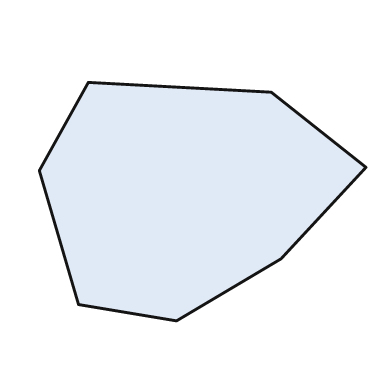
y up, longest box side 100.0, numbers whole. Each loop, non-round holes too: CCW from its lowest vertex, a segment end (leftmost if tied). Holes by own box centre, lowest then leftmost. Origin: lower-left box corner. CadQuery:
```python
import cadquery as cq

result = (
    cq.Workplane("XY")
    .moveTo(42.0, 0.0)
    .lineTo(74.0, 19.0)
    .lineTo(100.0, 47.0)
    .lineTo(71.0, 70.0)
    .lineTo(15.0, 73.0)
    .lineTo(0.0, 46.0)
    .lineTo(12.0, 5.0)
    .close()
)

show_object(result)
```